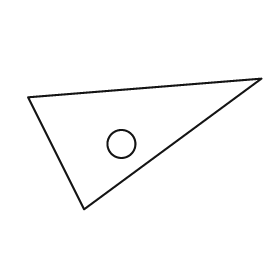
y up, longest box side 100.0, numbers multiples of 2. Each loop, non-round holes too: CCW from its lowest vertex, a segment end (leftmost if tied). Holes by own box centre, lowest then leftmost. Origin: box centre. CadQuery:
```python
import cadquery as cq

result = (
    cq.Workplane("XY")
    .moveTo(-26.0, -28.0)
    .lineTo(50.0, 28.0)
    .lineTo(-50.0, 20.0)
    .close()
    .moveTo(-10.0, 0.0)
    .circle(6.0)
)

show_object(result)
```